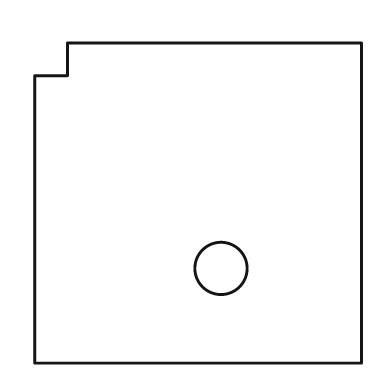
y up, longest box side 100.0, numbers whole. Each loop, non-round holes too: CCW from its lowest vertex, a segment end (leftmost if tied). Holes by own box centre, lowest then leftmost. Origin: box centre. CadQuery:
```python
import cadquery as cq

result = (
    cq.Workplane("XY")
    .moveTo(-50.0, -49.0)
    .lineTo(50.0, -49.0)
    .lineTo(50.0, 49.0)
    .lineTo(-40.0, 49.0)
    .lineTo(-40.0, 39.0)
    .lineTo(-50.0, 39.0)
    .close()
    .moveTo(7.0, -20.0)
    .circle(8.0)
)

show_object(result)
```